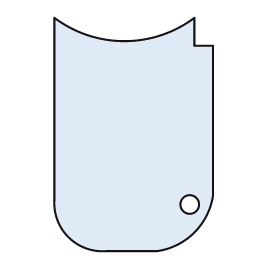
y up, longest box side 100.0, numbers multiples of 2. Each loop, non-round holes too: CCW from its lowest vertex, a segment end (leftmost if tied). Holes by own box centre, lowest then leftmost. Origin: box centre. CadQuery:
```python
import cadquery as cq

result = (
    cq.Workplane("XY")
    .moveTo(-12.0, -50.0)
    .lineTo(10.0, -50.0)
    .threePointArc((26.0, -42.0), (34.0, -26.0))
    .lineTo(34.0, 38.0)
    .lineTo(26.0, 38.0)
    .lineTo(26.0, 50.0)
    .threePointArc((-4.0, 40.0), (-34.0, 50.0))
    .lineTo(-34.0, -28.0)
    .threePointArc((-28.0, -44.0), (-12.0, -50.0))
    .close()
    .moveTo(24.0, -30.0)
    .circle(4.0)
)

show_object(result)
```